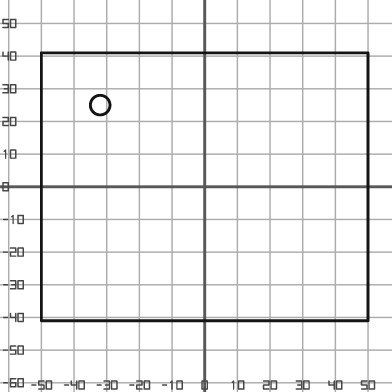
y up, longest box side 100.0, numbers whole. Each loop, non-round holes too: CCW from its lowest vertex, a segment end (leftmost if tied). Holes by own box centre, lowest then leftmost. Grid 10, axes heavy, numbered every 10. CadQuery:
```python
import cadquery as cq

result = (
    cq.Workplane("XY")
    .moveTo(-50.0, -41.0)
    .lineTo(50.0, -41.0)
    .lineTo(50.0, 41.0)
    .lineTo(-50.0, 41.0)
    .close()
    .moveTo(-32.0, 25.0)
    .circle(3.0)
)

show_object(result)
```